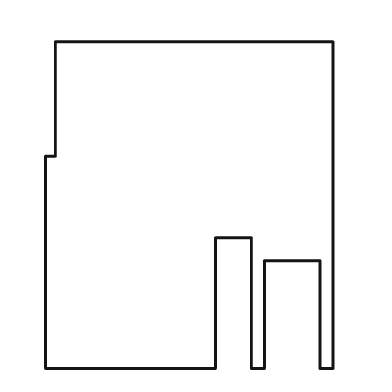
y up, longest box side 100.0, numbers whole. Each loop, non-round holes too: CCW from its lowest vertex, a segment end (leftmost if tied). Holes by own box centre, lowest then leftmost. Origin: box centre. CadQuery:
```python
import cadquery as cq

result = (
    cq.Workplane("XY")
    .moveTo(-44.0, -50.0)
    .lineTo(8.0, -50.0)
    .lineTo(8.0, -10.0)
    .lineTo(19.0, -10.0)
    .lineTo(19.0, -50.0)
    .lineTo(23.0, -50.0)
    .lineTo(23.0, -17.0)
    .lineTo(40.0, -17.0)
    .lineTo(40.0, -50.0)
    .lineTo(44.0, -50.0)
    .lineTo(44.0, 50.0)
    .lineTo(-41.0, 50.0)
    .lineTo(-41.0, 15.0)
    .lineTo(-44.0, 15.0)
    .close()
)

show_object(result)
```